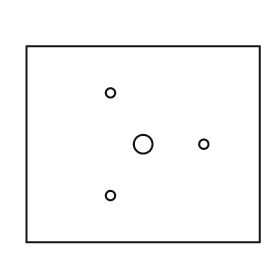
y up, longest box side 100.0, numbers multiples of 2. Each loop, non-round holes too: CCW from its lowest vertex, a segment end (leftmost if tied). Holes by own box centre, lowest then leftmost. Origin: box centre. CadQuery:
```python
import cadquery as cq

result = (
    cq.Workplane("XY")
    .moveTo(-50.0, -42.0)
    .lineTo(50.0, -42.0)
    .lineTo(50.0, 42.0)
    .lineTo(-50.0, 42.0)
    .close()
    .moveTo(-14.0, -22.0)
    .circle(2.0)
    .moveTo(0.0, 0.0)
    .circle(4.0)
    .moveTo(26.0, 0.0)
    .circle(2.0)
    .moveTo(-14.0, 22.0)
    .circle(2.0)
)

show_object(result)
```